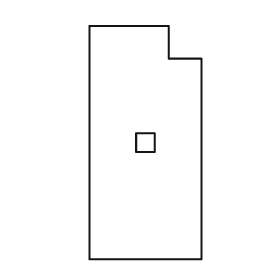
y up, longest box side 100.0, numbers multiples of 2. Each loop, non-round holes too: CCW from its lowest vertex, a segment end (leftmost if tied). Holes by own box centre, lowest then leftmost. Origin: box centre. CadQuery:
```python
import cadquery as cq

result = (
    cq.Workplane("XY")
    .moveTo(-24.0, -50.0)
    .lineTo(24.0, -50.0)
    .lineTo(24.0, 36.0)
    .lineTo(10.0, 36.0)
    .lineTo(10.0, 50.0)
    .lineTo(-24.0, 50.0)
    .close()
    .moveTo(-4.0, -4.0)
    .lineTo(4.0, -4.0)
    .lineTo(4.0, 4.0)
    .lineTo(-4.0, 4.0)
    .close()
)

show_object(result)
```